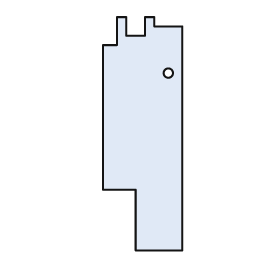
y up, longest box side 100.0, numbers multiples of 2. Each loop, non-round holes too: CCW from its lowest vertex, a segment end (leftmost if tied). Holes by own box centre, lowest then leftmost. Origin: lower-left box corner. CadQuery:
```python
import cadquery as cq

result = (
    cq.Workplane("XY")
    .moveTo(14.0, 0.0)
    .lineTo(34.0, 0.0)
    .lineTo(34.0, 96.0)
    .lineTo(22.0, 96.0)
    .lineTo(22.0, 100.0)
    .lineTo(18.0, 100.0)
    .lineTo(18.0, 92.0)
    .lineTo(10.0, 92.0)
    .lineTo(10.0, 100.0)
    .lineTo(6.0, 100.0)
    .lineTo(6.0, 88.0)
    .lineTo(0.0, 88.0)
    .lineTo(0.0, 26.0)
    .lineTo(14.0, 26.0)
    .close()
    .moveTo(28.0, 76.0)
    .circle(2.0)
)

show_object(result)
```